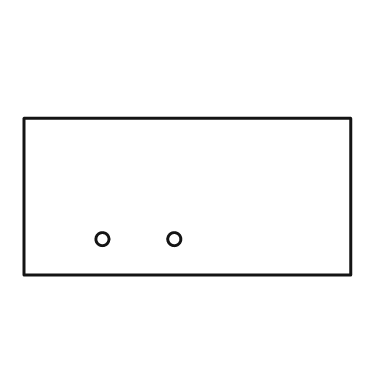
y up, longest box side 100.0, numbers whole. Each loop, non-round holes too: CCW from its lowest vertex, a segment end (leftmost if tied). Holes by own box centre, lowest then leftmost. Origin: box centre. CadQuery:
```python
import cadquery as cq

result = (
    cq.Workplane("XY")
    .moveTo(-50.0, -24.0)
    .lineTo(50.0, -24.0)
    .lineTo(50.0, 24.0)
    .lineTo(-50.0, 24.0)
    .close()
    .moveTo(-26.0, -13.0)
    .circle(2.0)
    .moveTo(-4.0, -13.0)
    .circle(2.0)
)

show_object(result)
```